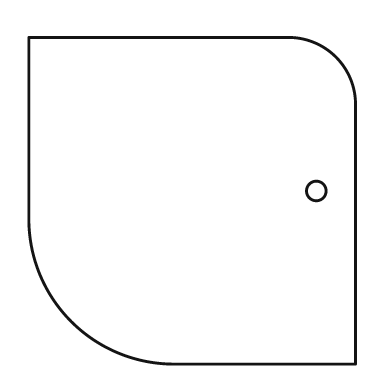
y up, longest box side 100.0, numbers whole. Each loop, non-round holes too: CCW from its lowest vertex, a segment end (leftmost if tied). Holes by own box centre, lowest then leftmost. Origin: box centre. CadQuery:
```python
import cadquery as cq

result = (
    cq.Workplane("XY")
    .moveTo(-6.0, -50.0)
    .lineTo(50.0, -50.0)
    .lineTo(50.0, 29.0)
    .threePointArc((44.0, 44.0), (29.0, 50.0))
    .lineTo(-50.0, 50.0)
    .lineTo(-50.0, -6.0)
    .threePointArc((-37.0, -37.0), (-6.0, -50.0))
    .close()
    .moveTo(38.0, 3.0)
    .circle(3.0)
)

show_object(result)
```